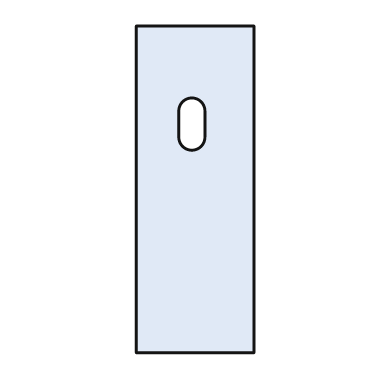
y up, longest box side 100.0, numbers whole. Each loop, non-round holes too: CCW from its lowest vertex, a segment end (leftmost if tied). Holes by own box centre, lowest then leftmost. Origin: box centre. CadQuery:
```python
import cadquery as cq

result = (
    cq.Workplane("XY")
    .moveTo(-18.0, -50.0)
    .lineTo(18.0, -50.0)
    .lineTo(18.0, 50.0)
    .lineTo(-18.0, 50.0)
    .close()
    .moveTo(-5.0, 16.0)
    .threePointArc((-1.0, 12.0), (3.0, 16.0))
    .lineTo(3.0, 24.0)
    .threePointArc((-1.0, 28.0), (-5.0, 24.0))
    .close()
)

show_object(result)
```